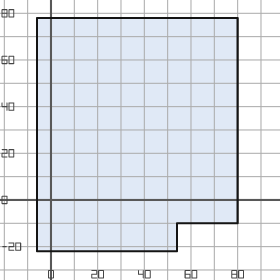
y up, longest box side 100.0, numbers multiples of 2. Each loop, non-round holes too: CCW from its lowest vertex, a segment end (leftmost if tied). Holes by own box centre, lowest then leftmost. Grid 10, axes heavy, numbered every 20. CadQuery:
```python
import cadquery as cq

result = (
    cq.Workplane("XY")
    .moveTo(-6.0, -22.0)
    .lineTo(54.0, -22.0)
    .lineTo(54.0, -10.0)
    .lineTo(80.0, -10.0)
    .lineTo(80.0, 78.0)
    .lineTo(-6.0, 78.0)
    .close()
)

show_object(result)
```